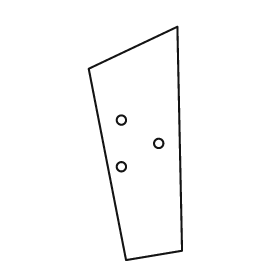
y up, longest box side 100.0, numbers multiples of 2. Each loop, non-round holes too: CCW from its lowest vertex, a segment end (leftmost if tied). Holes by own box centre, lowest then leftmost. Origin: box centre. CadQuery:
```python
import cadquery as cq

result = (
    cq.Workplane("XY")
    .moveTo(-4.0, -50.0)
    .lineTo(20.0, -46.0)
    .lineTo(18.0, 50.0)
    .lineTo(-20.0, 32.0)
    .close()
    .moveTo(-6.0, -10.0)
    .circle(2.0)
    .moveTo(10.0, 0.0)
    .circle(2.0)
    .moveTo(-6.0, 10.0)
    .circle(2.0)
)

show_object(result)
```